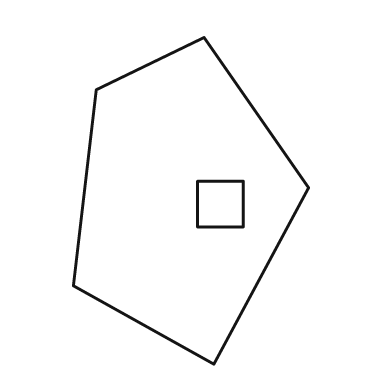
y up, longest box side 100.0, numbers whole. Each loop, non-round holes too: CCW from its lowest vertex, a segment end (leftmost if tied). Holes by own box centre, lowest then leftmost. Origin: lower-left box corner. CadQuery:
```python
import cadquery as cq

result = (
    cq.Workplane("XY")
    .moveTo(43.0, 0.0)
    .lineTo(72.0, 54.0)
    .lineTo(40.0, 100.0)
    .lineTo(7.0, 84.0)
    .lineTo(0.0, 24.0)
    .close()
    .moveTo(38.0, 42.0)
    .lineTo(52.0, 42.0)
    .lineTo(52.0, 56.0)
    .lineTo(38.0, 56.0)
    .close()
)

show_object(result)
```